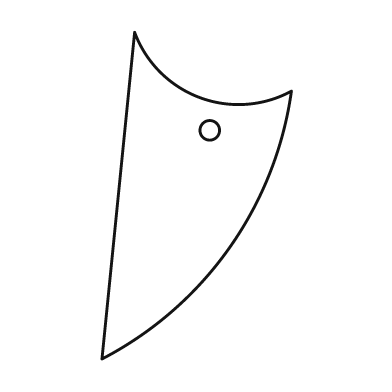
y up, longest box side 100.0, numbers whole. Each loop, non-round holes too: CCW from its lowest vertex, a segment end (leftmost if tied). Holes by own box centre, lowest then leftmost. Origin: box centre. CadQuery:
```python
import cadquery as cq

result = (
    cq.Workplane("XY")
    .moveTo(-29.0, -50.0)
    .threePointArc((10.0, -16.0), (29.0, 32.0))
    .threePointArc((1.0, 30.0), (-19.0, 50.0))
    .close()
    .moveTo(4.0, 20.0)
    .circle(3.0)
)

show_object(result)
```